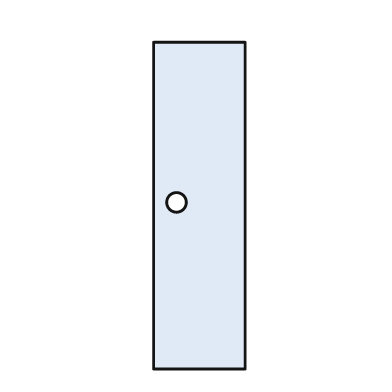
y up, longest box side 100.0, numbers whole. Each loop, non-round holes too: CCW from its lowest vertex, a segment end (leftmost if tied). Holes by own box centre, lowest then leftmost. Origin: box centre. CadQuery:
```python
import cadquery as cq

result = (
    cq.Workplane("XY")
    .moveTo(-14.0, -50.0)
    .lineTo(14.0, -50.0)
    .lineTo(14.0, 50.0)
    .lineTo(-14.0, 50.0)
    .close()
    .moveTo(-7.0, 1.0)
    .circle(3.0)
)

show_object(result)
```